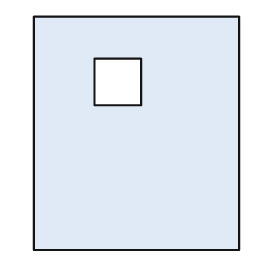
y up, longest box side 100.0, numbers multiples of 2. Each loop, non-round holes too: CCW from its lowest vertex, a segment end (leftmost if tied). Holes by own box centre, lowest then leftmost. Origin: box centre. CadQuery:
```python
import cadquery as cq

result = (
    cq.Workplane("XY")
    .moveTo(-44.0, -50.0)
    .lineTo(44.0, -50.0)
    .lineTo(44.0, 50.0)
    .lineTo(-44.0, 50.0)
    .close()
    .moveTo(-18.0, 12.0)
    .lineTo(2.0, 12.0)
    .lineTo(2.0, 32.0)
    .lineTo(-18.0, 32.0)
    .close()
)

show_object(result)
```